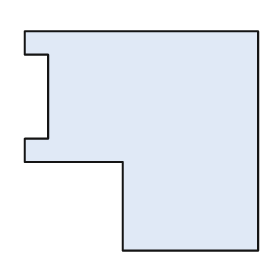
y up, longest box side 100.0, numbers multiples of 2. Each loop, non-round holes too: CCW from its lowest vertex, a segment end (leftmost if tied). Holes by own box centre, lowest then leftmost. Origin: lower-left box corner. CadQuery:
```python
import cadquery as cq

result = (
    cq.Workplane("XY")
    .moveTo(42.0, 0.0)
    .lineTo(100.0, 0.0)
    .lineTo(100.0, 94.0)
    .lineTo(0.0, 94.0)
    .lineTo(0.0, 84.0)
    .lineTo(10.0, 84.0)
    .lineTo(10.0, 48.0)
    .lineTo(0.0, 48.0)
    .lineTo(0.0, 38.0)
    .lineTo(42.0, 38.0)
    .close()
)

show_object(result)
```